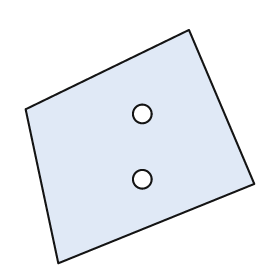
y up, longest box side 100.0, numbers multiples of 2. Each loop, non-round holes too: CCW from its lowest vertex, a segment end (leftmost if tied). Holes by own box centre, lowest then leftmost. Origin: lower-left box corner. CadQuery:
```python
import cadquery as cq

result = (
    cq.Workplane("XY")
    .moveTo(14.0, 0.0)
    .lineTo(98.0, 34.0)
    .lineTo(70.0, 100.0)
    .lineTo(0.0, 66.0)
    .close()
    .moveTo(50.0, 36.0)
    .circle(4.0)
    .moveTo(50.0, 64.0)
    .circle(4.0)
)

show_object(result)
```